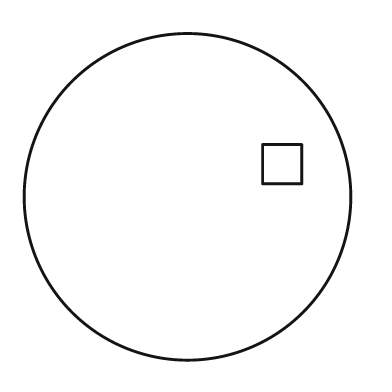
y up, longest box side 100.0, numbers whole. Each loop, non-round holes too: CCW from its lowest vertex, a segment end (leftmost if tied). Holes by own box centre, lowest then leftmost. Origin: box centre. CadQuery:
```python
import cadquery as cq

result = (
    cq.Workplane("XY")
    .moveTo(0.0, 0.0)
    .circle(50.0)
    .moveTo(23.0, 4.0)
    .lineTo(35.0, 4.0)
    .lineTo(35.0, 16.0)
    .lineTo(23.0, 16.0)
    .close()
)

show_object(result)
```